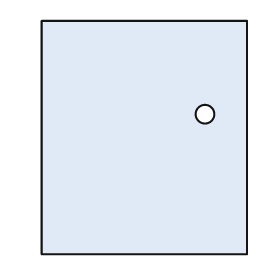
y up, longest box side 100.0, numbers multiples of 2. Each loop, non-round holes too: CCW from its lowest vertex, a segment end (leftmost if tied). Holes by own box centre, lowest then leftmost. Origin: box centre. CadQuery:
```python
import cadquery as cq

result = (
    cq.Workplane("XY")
    .moveTo(-44.0, -50.0)
    .lineTo(44.0, -50.0)
    .lineTo(44.0, 50.0)
    .lineTo(-44.0, 50.0)
    .close()
    .moveTo(26.0, 10.0)
    .circle(4.0)
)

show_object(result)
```